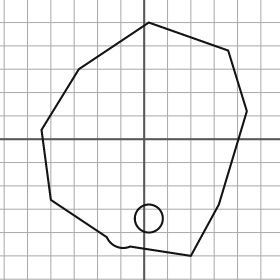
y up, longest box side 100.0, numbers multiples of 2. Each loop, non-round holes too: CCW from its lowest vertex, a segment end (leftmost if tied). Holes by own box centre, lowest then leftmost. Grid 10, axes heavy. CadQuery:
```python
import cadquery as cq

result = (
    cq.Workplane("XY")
    .moveTo(20.0, -50.0)
    .lineTo(32.0, -28.0)
    .lineTo(44.0, 12.0)
    .lineTo(36.0, 38.0)
    .lineTo(2.0, 50.0)
    .lineTo(-28.0, 30.0)
    .lineTo(-44.0, 4.0)
    .lineTo(-40.0, -26.0)
    .lineTo(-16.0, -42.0)
    .threePointArc((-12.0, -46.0), (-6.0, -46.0))
    .close()
    .moveTo(2.0, -34.0)
    .circle(6.0)
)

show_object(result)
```